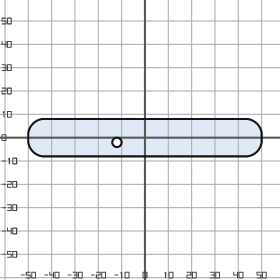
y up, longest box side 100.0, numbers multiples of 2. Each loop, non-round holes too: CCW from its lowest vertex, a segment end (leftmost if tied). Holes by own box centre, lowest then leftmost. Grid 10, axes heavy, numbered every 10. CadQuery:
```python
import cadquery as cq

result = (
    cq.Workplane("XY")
    .moveTo(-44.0, -8.0)
    .lineTo(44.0, -8.0)
    .threePointArc((48.0, -6.0), (50.0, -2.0))
    .lineTo(50.0, 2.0)
    .threePointArc((48.0, 6.0), (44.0, 8.0))
    .lineTo(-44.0, 8.0)
    .threePointArc((-48.0, 6.0), (-50.0, 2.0))
    .lineTo(-50.0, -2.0)
    .threePointArc((-48.0, -6.0), (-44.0, -8.0))
    .close()
    .moveTo(-12.0, -2.0)
    .circle(2.0)
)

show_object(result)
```